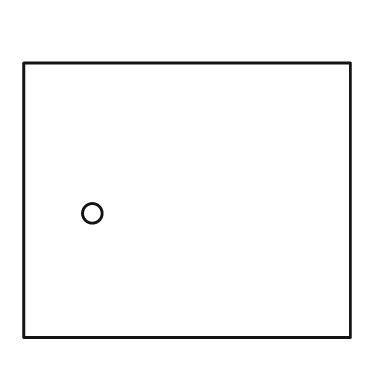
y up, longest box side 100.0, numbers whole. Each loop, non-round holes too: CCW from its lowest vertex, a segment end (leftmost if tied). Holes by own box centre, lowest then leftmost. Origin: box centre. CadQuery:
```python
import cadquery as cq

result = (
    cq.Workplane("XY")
    .moveTo(-50.0, -42.0)
    .lineTo(50.0, -42.0)
    .lineTo(50.0, 42.0)
    .lineTo(-50.0, 42.0)
    .close()
    .moveTo(-29.0, -4.0)
    .circle(3.0)
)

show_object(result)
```